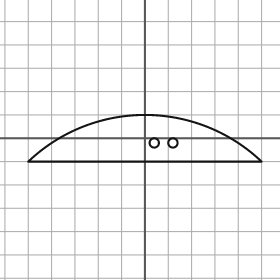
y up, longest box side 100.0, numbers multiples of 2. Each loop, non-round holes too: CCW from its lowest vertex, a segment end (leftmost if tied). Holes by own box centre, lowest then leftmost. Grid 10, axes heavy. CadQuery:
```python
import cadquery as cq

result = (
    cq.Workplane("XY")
    .moveTo(-50.0, -10.0)
    .lineTo(50.0, -10.0)
    .threePointArc((0.0, 10.0), (-50.0, -10.0))
    .close()
    .moveTo(4.0, -2.0)
    .circle(2.0)
    .moveTo(12.0, -2.0)
    .circle(2.0)
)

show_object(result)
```